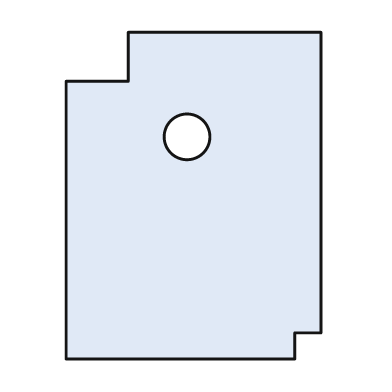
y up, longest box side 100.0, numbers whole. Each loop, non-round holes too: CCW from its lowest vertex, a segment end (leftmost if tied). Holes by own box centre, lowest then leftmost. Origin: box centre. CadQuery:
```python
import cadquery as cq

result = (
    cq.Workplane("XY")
    .moveTo(-39.0, -50.0)
    .lineTo(31.0, -50.0)
    .lineTo(31.0, -42.0)
    .lineTo(39.0, -42.0)
    .lineTo(39.0, 50.0)
    .lineTo(-20.0, 50.0)
    .lineTo(-20.0, 35.0)
    .lineTo(-39.0, 35.0)
    .close()
    .moveTo(-2.0, 18.0)
    .circle(7.0)
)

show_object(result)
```